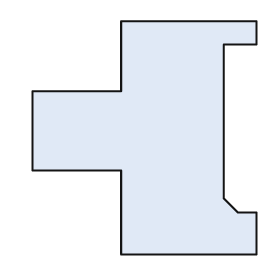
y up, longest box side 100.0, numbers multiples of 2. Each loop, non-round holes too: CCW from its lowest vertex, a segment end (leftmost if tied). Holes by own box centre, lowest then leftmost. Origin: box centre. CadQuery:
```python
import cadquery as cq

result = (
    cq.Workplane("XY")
    .moveTo(-10.0, -50.0)
    .lineTo(48.0, -50.0)
    .lineTo(48.0, -32.0)
    .lineTo(40.0, -32.0)
    .lineTo(34.0, -26.0)
    .lineTo(34.0, 40.0)
    .lineTo(48.0, 40.0)
    .lineTo(48.0, 50.0)
    .lineTo(-10.0, 50.0)
    .lineTo(-10.0, 20.0)
    .lineTo(-48.0, 20.0)
    .lineTo(-48.0, -14.0)
    .lineTo(-10.0, -14.0)
    .close()
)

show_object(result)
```